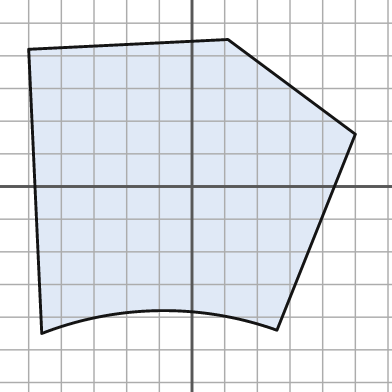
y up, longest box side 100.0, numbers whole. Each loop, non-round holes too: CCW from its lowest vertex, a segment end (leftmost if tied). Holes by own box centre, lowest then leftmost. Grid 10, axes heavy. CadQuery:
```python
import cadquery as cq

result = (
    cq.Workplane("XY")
    .moveTo(-46.0, -45.0)
    .threePointArc((-10.0, -38.0), (26.0, -44.0))
    .lineTo(50.0, 16.0)
    .lineTo(11.0, 45.0)
    .lineTo(-50.0, 42.0)
    .close()
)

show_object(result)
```